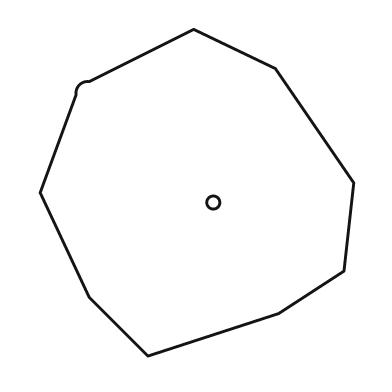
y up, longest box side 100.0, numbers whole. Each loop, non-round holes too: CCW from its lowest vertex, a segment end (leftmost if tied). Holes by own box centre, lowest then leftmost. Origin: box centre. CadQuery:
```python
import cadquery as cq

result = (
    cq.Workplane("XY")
    .moveTo(-15.0, -50.0)
    .lineTo(25.0, -37.0)
    .lineTo(45.0, -24.0)
    .lineTo(48.0, 3.0)
    .lineTo(24.0, 38.0)
    .lineTo(-1.0, 50.0)
    .lineTo(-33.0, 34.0)
    .threePointArc((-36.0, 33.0), (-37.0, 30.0))
    .lineTo(-48.0, 0.0)
    .lineTo(-33.0, -32.0)
    .close()
    .moveTo(5.0, -3.0)
    .circle(2.0)
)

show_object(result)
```